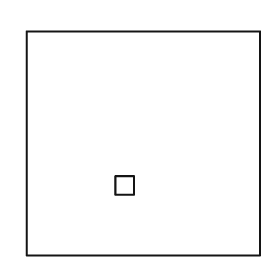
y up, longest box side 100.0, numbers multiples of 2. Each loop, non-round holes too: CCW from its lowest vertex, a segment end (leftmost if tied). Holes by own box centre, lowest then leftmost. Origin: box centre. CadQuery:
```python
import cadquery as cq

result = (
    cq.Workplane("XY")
    .moveTo(-50.0, -48.0)
    .lineTo(50.0, -48.0)
    .lineTo(50.0, 48.0)
    .lineTo(-50.0, 48.0)
    .close()
    .moveTo(-12.0, -22.0)
    .lineTo(-4.0, -22.0)
    .lineTo(-4.0, -14.0)
    .lineTo(-12.0, -14.0)
    .close()
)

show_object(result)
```